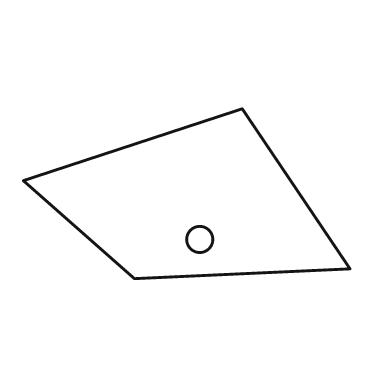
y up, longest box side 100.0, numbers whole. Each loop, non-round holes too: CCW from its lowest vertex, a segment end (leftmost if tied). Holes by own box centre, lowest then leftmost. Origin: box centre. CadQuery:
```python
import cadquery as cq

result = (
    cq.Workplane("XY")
    .moveTo(-16.0, -26.0)
    .lineTo(50.0, -23.0)
    .lineTo(17.0, 26.0)
    .lineTo(-50.0, 4.0)
    .close()
    .moveTo(4.0, -14.0)
    .circle(4.0)
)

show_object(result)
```